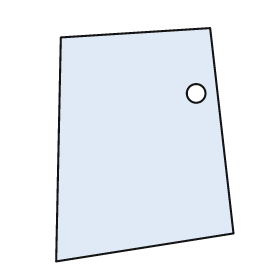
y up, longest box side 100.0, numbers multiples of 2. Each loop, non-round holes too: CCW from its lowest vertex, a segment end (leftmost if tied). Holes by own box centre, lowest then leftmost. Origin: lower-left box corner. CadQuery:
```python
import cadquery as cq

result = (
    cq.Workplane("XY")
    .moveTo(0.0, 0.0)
    .lineTo(76.0, 12.0)
    .lineTo(66.0, 100.0)
    .lineTo(2.0, 96.0)
    .close()
    .moveTo(60.0, 72.0)
    .circle(4.0)
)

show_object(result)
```